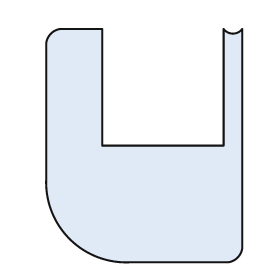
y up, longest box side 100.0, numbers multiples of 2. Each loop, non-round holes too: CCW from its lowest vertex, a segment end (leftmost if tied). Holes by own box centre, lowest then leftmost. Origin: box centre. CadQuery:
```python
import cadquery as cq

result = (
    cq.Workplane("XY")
    .moveTo(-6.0, -50.0)
    .lineTo(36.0, -50.0)
    .threePointArc((40.0, -48.0), (42.0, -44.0))
    .lineTo(42.0, 50.0)
    .threePointArc((38.0, 48.0), (34.0, 50.0))
    .lineTo(34.0, 0.0)
    .lineTo(-18.0, 0.0)
    .lineTo(-18.0, 50.0)
    .lineTo(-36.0, 50.0)
    .threePointArc((-40.0, 48.0), (-42.0, 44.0))
    .lineTo(-42.0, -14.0)
    .threePointArc((-32.0, -40.0), (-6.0, -50.0))
    .close()
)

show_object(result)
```